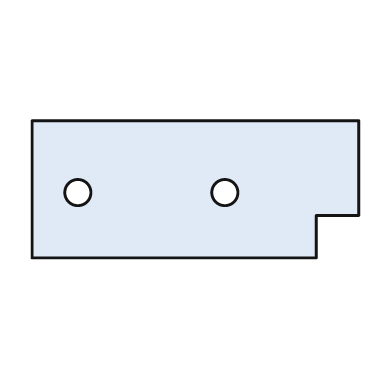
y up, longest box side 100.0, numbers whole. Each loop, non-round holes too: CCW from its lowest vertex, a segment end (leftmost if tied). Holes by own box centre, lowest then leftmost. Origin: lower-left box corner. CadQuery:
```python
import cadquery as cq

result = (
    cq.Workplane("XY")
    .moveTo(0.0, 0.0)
    .lineTo(87.0, 0.0)
    .lineTo(87.0, 13.0)
    .lineTo(100.0, 13.0)
    .lineTo(100.0, 42.0)
    .lineTo(0.0, 42.0)
    .close()
    .moveTo(14.0, 20.0)
    .circle(4.0)
    .moveTo(59.0, 20.0)
    .circle(4.0)
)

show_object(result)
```